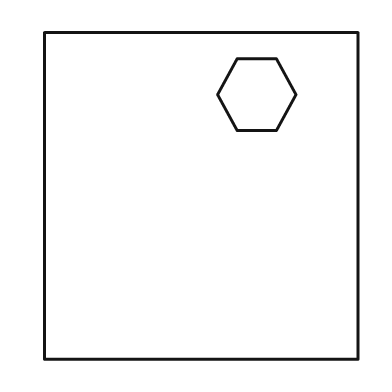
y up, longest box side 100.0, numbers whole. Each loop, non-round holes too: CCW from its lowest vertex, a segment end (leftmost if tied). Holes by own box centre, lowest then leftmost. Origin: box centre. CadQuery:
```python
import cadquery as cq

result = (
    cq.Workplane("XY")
    .moveTo(-48.0, -50.0)
    .lineTo(48.0, -50.0)
    .lineTo(48.0, 50.0)
    .lineTo(-48.0, 50.0)
    .close()
    .moveTo(11.0, 20.0)
    .lineTo(23.0, 20.0)
    .lineTo(29.0, 31.0)
    .lineTo(23.0, 42.0)
    .lineTo(11.0, 42.0)
    .lineTo(5.0, 31.0)
    .close()
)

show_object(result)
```